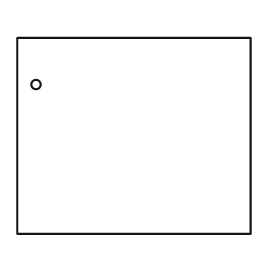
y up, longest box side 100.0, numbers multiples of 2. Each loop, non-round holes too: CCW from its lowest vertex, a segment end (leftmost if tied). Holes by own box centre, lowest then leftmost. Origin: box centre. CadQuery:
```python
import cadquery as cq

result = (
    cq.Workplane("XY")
    .moveTo(-50.0, -42.0)
    .lineTo(50.0, -42.0)
    .lineTo(50.0, 42.0)
    .lineTo(-50.0, 42.0)
    .close()
    .moveTo(-42.0, 22.0)
    .circle(2.0)
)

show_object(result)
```